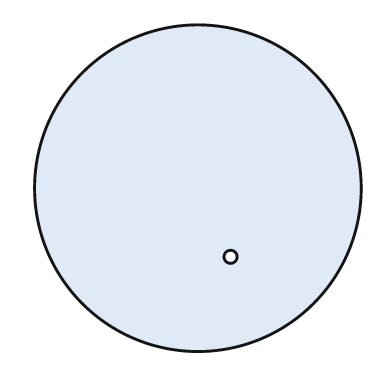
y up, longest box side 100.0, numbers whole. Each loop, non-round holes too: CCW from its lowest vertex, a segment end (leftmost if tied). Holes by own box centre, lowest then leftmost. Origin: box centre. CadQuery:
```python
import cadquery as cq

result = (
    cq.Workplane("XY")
    .moveTo(0.0, 0.0)
    .circle(50.0)
    .moveTo(10.0, -21.0)
    .circle(2.0)
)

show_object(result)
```